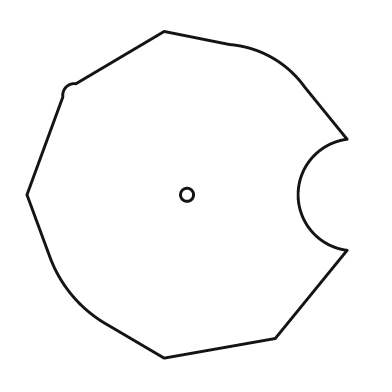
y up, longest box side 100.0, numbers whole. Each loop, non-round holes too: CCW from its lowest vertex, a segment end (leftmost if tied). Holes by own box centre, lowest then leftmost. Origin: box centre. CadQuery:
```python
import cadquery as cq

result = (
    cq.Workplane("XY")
    .moveTo(-7.0, -50.0)
    .lineTo(27.0, -44.0)
    .lineTo(49.0, -17.0)
    .threePointArc((34.0, 0.0), (49.0, 17.0))
    .lineTo(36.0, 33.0)
    .threePointArc((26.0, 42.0), (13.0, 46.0))
    .lineTo(-7.0, 50.0)
    .lineTo(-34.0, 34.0)
    .threePointArc((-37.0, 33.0), (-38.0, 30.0))
    .lineTo(-49.0, 0.0)
    .lineTo(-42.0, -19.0)
    .threePointArc((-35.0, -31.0), (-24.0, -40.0))
    .close()
    .moveTo(0.0, 0.0)
    .circle(2.0)
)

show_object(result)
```